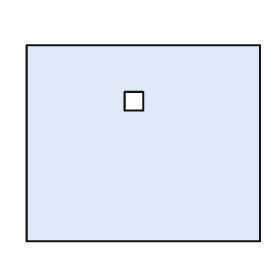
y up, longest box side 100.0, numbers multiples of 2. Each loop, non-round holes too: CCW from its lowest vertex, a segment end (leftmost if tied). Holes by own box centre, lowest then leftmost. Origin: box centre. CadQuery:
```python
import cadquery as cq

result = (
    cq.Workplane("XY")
    .moveTo(-50.0, -42.0)
    .lineTo(50.0, -42.0)
    .lineTo(50.0, 42.0)
    .lineTo(-50.0, 42.0)
    .close()
    .moveTo(-8.0, 14.0)
    .lineTo(0.0, 14.0)
    .lineTo(0.0, 22.0)
    .lineTo(-8.0, 22.0)
    .close()
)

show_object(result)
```